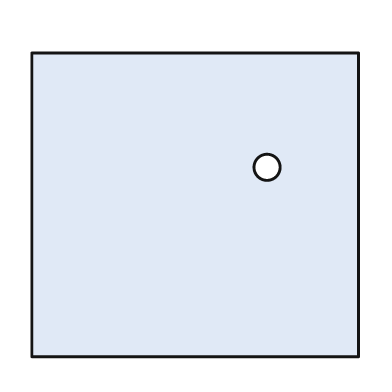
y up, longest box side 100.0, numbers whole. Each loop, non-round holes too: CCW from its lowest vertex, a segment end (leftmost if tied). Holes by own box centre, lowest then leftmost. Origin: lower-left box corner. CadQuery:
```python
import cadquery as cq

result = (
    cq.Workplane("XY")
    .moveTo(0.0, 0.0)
    .lineTo(100.0, 0.0)
    .lineTo(100.0, 93.0)
    .lineTo(0.0, 93.0)
    .close()
    .moveTo(72.0, 58.0)
    .circle(4.0)
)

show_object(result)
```